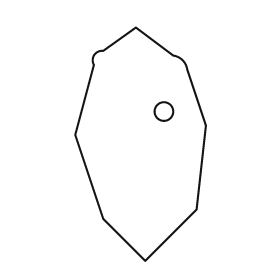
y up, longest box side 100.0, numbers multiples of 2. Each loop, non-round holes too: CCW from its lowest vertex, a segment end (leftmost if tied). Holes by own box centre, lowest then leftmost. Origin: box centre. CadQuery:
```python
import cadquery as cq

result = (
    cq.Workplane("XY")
    .moveTo(2.0, -50.0)
    .lineTo(24.0, -28.0)
    .lineTo(28.0, 8.0)
    .lineTo(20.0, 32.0)
    .threePointArc((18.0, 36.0), (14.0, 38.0))
    .lineTo(-2.0, 50.0)
    .lineTo(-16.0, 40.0)
    .threePointArc((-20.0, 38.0), (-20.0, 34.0))
    .lineTo(-28.0, 4.0)
    .lineTo(-16.0, -32.0)
    .close()
    .moveTo(10.0, 14.0)
    .circle(4.0)
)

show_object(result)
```